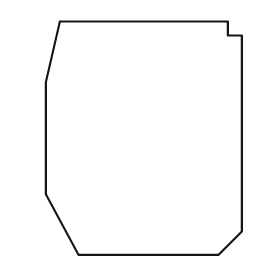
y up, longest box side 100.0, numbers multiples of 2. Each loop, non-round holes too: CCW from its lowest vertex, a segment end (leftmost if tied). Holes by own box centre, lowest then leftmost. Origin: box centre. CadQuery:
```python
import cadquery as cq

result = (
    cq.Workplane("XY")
    .moveTo(-28.0, -50.0)
    .lineTo(32.0, -50.0)
    .lineTo(42.0, -40.0)
    .lineTo(42.0, 44.0)
    .lineTo(36.0, 44.0)
    .lineTo(36.0, 50.0)
    .lineTo(-36.0, 50.0)
    .lineTo(-42.0, 24.0)
    .lineTo(-42.0, -24.0)
    .close()
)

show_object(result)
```